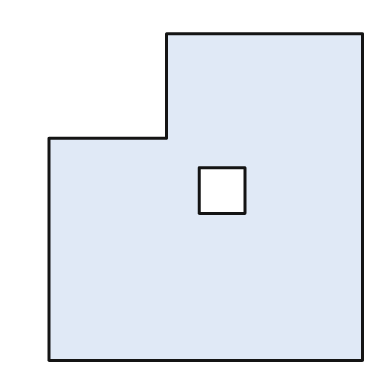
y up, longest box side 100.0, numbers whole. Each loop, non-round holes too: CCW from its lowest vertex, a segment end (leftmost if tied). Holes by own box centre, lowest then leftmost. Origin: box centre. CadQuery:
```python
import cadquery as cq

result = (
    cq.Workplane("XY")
    .moveTo(-48.0, -50.0)
    .lineTo(48.0, -50.0)
    .lineTo(48.0, 50.0)
    .lineTo(-12.0, 50.0)
    .lineTo(-12.0, 18.0)
    .lineTo(-48.0, 18.0)
    .close()
    .moveTo(-2.0, -5.0)
    .lineTo(12.0, -5.0)
    .lineTo(12.0, 9.0)
    .lineTo(-2.0, 9.0)
    .close()
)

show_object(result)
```